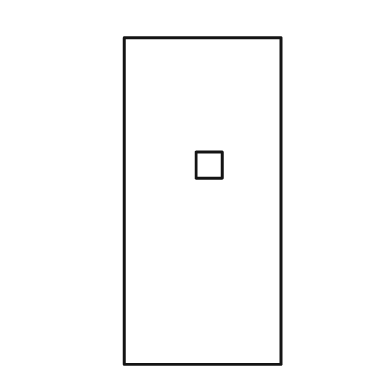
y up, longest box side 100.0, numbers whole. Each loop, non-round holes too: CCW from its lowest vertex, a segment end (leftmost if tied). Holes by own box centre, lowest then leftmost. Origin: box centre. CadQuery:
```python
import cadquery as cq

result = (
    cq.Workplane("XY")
    .moveTo(-24.0, -50.0)
    .lineTo(24.0, -50.0)
    .lineTo(24.0, 50.0)
    .lineTo(-24.0, 50.0)
    .close()
    .moveTo(-2.0, 7.0)
    .lineTo(6.0, 7.0)
    .lineTo(6.0, 15.0)
    .lineTo(-2.0, 15.0)
    .close()
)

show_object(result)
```